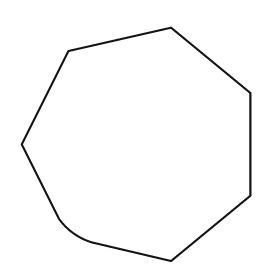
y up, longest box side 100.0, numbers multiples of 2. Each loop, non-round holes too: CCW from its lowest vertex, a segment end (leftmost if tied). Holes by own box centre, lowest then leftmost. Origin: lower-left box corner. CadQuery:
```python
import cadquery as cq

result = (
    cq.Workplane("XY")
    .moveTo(64.0, 0.0)
    .lineTo(98.0, 28.0)
    .lineTo(98.0, 72.0)
    .lineTo(64.0, 100.0)
    .lineTo(20.0, 90.0)
    .lineTo(0.0, 50.0)
    .lineTo(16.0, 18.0)
    .threePointArc((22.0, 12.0), (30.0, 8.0))
    .close()
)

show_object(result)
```